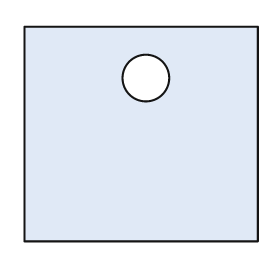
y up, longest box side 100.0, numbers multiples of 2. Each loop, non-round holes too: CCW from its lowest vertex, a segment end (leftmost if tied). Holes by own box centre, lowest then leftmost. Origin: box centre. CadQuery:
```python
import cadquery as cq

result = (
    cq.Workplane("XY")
    .moveTo(-50.0, -46.0)
    .lineTo(50.0, -46.0)
    .lineTo(50.0, 46.0)
    .lineTo(-50.0, 46.0)
    .close()
    .moveTo(2.0, 24.0)
    .circle(10.0)
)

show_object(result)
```